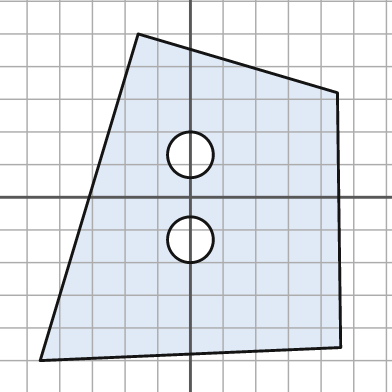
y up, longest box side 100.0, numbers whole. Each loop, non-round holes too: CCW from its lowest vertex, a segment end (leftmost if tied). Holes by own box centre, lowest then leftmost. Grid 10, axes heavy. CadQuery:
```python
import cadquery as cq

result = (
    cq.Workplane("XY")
    .moveTo(-46.0, -50.0)
    .lineTo(46.0, -46.0)
    .lineTo(45.0, 32.0)
    .lineTo(-16.0, 50.0)
    .close()
    .moveTo(0.0, -13.0)
    .circle(7.0)
    .moveTo(0.0, 13.0)
    .circle(7.0)
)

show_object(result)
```